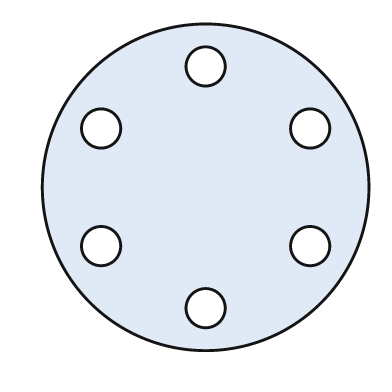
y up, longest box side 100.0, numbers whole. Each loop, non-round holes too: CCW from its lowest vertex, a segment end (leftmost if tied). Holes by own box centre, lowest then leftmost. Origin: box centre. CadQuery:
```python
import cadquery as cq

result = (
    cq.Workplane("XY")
    .moveTo(0.0, 0.0)
    .circle(50.0)
    .moveTo(0.0, -37.0)
    .circle(6.0)
    .moveTo(-32.0, -18.0)
    .circle(6.0)
    .moveTo(32.0, -18.0)
    .circle(6.0)
    .moveTo(-32.0, 18.0)
    .circle(6.0)
    .moveTo(32.0, 18.0)
    .circle(6.0)
    .moveTo(0.0, 37.0)
    .circle(6.0)
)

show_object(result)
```